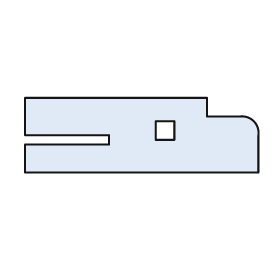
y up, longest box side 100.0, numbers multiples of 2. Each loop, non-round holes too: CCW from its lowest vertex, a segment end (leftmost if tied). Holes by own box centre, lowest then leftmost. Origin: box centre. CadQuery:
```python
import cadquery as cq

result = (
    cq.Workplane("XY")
    .moveTo(-50.0, -16.0)
    .lineTo(50.0, -16.0)
    .lineTo(50.0, 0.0)
    .threePointArc((48.0, 6.0), (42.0, 8.0))
    .lineTo(28.0, 8.0)
    .lineTo(28.0, 16.0)
    .lineTo(-50.0, 16.0)
    .lineTo(-50.0, 0.0)
    .lineTo(-14.0, 0.0)
    .lineTo(-14.0, -4.0)
    .lineTo(-50.0, -4.0)
    .close()
    .moveTo(6.0, -2.0)
    .lineTo(14.0, -2.0)
    .lineTo(14.0, 6.0)
    .lineTo(6.0, 6.0)
    .close()
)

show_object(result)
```